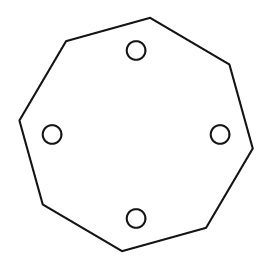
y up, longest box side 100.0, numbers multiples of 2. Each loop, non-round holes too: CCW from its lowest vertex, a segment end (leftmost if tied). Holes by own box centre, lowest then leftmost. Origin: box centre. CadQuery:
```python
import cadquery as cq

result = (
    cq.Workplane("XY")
    .moveTo(-6.0, -50.0)
    .lineTo(30.0, -40.0)
    .lineTo(50.0, -6.0)
    .lineTo(40.0, 30.0)
    .lineTo(6.0, 50.0)
    .lineTo(-30.0, 40.0)
    .lineTo(-50.0, 6.0)
    .lineTo(-40.0, -30.0)
    .close()
    .moveTo(0.0, -36.0)
    .circle(4.0)
    .moveTo(-36.0, 0.0)
    .circle(4.0)
    .moveTo(36.0, 0.0)
    .circle(4.0)
    .moveTo(0.0, 36.0)
    .circle(4.0)
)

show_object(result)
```